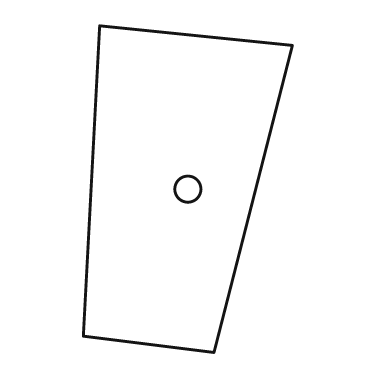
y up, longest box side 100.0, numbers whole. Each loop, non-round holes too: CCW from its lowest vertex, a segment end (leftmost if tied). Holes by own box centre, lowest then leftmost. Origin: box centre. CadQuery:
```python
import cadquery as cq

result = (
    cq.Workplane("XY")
    .moveTo(8.0, -50.0)
    .lineTo(32.0, 44.0)
    .lineTo(-27.0, 50.0)
    .lineTo(-32.0, -45.0)
    .close()
    .moveTo(0.0, 0.0)
    .circle(4.0)
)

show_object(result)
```